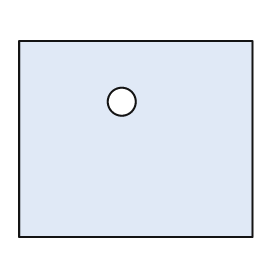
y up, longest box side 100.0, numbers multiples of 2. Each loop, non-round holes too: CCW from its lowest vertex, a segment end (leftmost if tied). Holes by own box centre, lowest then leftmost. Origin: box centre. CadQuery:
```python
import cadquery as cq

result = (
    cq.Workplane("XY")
    .moveTo(-50.0, -42.0)
    .lineTo(50.0, -42.0)
    .lineTo(50.0, 42.0)
    .lineTo(-50.0, 42.0)
    .close()
    .moveTo(-6.0, 16.0)
    .circle(6.0)
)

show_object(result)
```